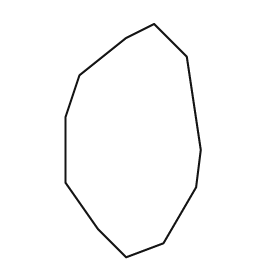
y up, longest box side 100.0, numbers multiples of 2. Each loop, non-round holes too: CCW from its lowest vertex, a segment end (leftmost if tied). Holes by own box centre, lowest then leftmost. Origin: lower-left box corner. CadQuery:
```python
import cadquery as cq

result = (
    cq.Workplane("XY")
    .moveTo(26.0, 0.0)
    .lineTo(42.0, 6.0)
    .lineTo(56.0, 30.0)
    .lineTo(58.0, 46.0)
    .lineTo(52.0, 86.0)
    .lineTo(38.0, 100.0)
    .lineTo(26.0, 94.0)
    .lineTo(6.0, 78.0)
    .lineTo(0.0, 60.0)
    .lineTo(0.0, 32.0)
    .lineTo(14.0, 12.0)
    .close()
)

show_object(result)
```